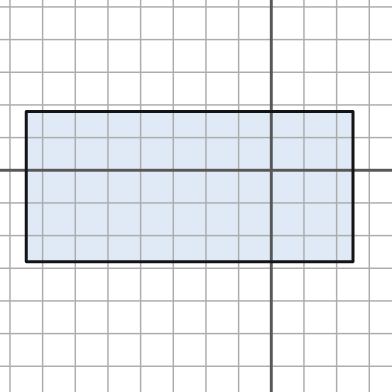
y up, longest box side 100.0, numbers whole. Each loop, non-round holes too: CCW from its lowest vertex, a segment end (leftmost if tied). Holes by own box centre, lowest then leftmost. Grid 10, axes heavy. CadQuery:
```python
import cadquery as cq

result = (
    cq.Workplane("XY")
    .moveTo(-75.0, -28.0)
    .lineTo(25.0, -28.0)
    .lineTo(25.0, 18.0)
    .lineTo(-75.0, 18.0)
    .close()
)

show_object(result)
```